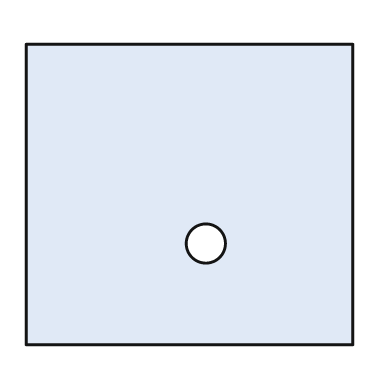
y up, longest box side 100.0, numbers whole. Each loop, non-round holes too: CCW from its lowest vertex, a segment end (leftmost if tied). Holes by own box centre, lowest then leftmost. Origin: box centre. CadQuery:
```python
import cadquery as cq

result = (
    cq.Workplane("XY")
    .moveTo(-50.0, -46.0)
    .lineTo(50.0, -46.0)
    .lineTo(50.0, 46.0)
    .lineTo(-50.0, 46.0)
    .close()
    .moveTo(5.0, -15.0)
    .circle(6.0)
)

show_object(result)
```